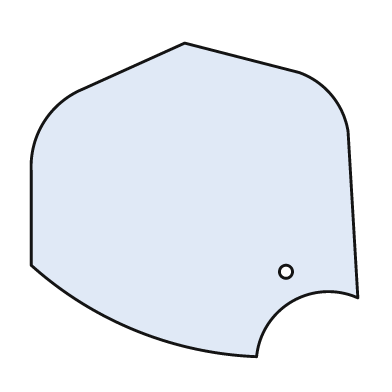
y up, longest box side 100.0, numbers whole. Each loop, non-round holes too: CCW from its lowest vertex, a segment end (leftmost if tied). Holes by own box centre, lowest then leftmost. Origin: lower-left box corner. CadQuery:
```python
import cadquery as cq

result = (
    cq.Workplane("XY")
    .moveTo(69.0, 0.0)
    .threePointArc((80.0, 17.0), (100.0, 18.0))
    .lineTo(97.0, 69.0)
    .threePointArc((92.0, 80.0), (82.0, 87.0))
    .lineTo(47.0, 96.0)
    .lineTo(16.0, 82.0)
    .threePointArc((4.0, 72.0), (0.0, 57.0))
    .lineTo(0.0, 28.0)
    .threePointArc((32.0, 8.0), (69.0, 0.0))
    .close()
    .moveTo(78.0, 26.0)
    .circle(2.0)
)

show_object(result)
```